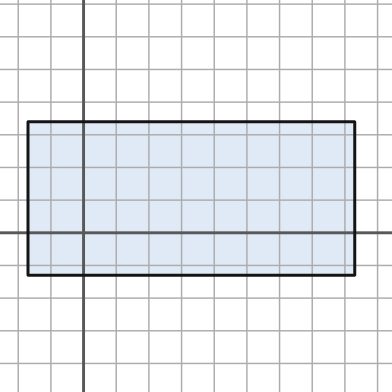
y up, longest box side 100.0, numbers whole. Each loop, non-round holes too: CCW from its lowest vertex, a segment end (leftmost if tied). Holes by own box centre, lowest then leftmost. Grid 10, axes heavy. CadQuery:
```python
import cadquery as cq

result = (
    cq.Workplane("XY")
    .moveTo(-17.0, -13.0)
    .lineTo(83.0, -13.0)
    .lineTo(83.0, 34.0)
    .lineTo(-17.0, 34.0)
    .close()
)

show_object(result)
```